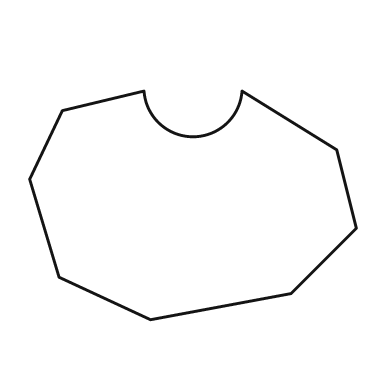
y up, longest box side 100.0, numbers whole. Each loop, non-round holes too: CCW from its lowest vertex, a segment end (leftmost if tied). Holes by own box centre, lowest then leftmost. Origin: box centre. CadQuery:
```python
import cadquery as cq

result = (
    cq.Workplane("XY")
    .moveTo(-13.0, -35.0)
    .lineTo(30.0, -27.0)
    .lineTo(50.0, -7.0)
    .lineTo(44.0, 17.0)
    .lineTo(15.0, 35.0)
    .threePointArc((0.0, 21.0), (-15.0, 35.0))
    .lineTo(-40.0, 29.0)
    .lineTo(-50.0, 8.0)
    .lineTo(-41.0, -22.0)
    .close()
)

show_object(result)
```